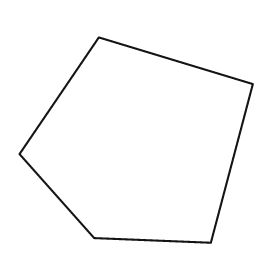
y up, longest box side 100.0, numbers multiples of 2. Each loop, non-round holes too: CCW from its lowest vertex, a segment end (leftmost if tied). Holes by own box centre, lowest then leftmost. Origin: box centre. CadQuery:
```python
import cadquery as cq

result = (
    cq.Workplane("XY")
    .moveTo(32.0, -44.0)
    .lineTo(50.0, 24.0)
    .lineTo(-16.0, 44.0)
    .lineTo(-50.0, -6.0)
    .lineTo(-18.0, -42.0)
    .close()
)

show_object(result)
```